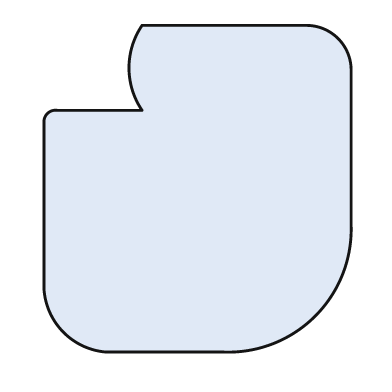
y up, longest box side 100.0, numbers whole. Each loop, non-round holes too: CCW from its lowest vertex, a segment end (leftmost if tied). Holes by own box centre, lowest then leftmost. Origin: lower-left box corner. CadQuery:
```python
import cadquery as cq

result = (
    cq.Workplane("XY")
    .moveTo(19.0, 0.0)
    .lineTo(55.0, 0.0)
    .threePointArc((83.0, 11.0), (94.0, 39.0))
    .lineTo(94.0, 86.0)
    .threePointArc((90.0, 96.0), (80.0, 100.0))
    .lineTo(30.0, 100.0)
    .threePointArc((26.0, 87.0), (30.0, 74.0))
    .lineTo(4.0, 74.0)
    .threePointArc((1.0, 73.0), (0.0, 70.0))
    .lineTo(0.0, 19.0)
    .threePointArc((6.0, 6.0), (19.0, 0.0))
    .close()
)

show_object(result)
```